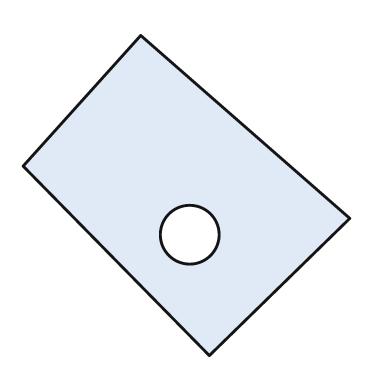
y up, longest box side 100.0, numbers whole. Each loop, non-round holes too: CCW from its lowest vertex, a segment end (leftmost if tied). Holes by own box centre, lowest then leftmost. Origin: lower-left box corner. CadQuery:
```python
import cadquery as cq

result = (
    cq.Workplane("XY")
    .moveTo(57.0, 0.0)
    .lineTo(100.0, 42.0)
    .lineTo(36.0, 98.0)
    .lineTo(0.0, 58.0)
    .close()
    .moveTo(51.0, 37.0)
    .circle(9.0)
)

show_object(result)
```